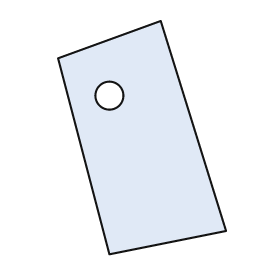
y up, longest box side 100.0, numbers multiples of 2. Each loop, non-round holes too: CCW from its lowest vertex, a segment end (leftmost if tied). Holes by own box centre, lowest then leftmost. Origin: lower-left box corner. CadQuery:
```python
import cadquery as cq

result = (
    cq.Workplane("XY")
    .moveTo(22.0, 0.0)
    .lineTo(72.0, 10.0)
    .lineTo(44.0, 100.0)
    .lineTo(0.0, 84.0)
    .close()
    .moveTo(22.0, 68.0)
    .circle(6.0)
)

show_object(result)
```